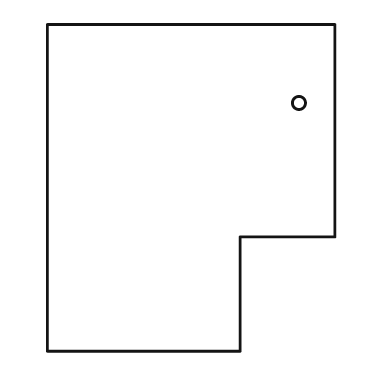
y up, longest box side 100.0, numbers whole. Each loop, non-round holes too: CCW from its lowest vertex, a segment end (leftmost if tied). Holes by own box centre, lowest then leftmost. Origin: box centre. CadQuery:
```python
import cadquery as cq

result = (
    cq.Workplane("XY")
    .moveTo(-44.0, -50.0)
    .lineTo(15.0, -50.0)
    .lineTo(15.0, -15.0)
    .lineTo(44.0, -15.0)
    .lineTo(44.0, 50.0)
    .lineTo(-44.0, 50.0)
    .close()
    .moveTo(33.0, 26.0)
    .circle(2.0)
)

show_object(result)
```